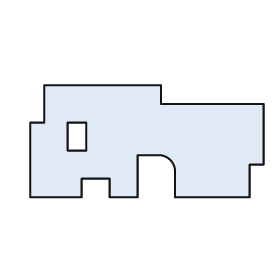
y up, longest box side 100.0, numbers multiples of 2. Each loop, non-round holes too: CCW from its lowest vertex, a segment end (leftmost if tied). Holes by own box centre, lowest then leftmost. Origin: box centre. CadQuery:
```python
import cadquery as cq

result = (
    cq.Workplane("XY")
    .moveTo(-50.0, -24.0)
    .lineTo(-28.0, -24.0)
    .lineTo(-28.0, -16.0)
    .lineTo(-16.0, -16.0)
    .lineTo(-16.0, -24.0)
    .lineTo(-4.0, -24.0)
    .lineTo(-4.0, -6.0)
    .lineTo(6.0, -6.0)
    .threePointArc((10.0, -8.0), (12.0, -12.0))
    .lineTo(12.0, -24.0)
    .lineTo(44.0, -24.0)
    .lineTo(44.0, -10.0)
    .lineTo(50.0, -10.0)
    .lineTo(50.0, 16.0)
    .lineTo(6.0, 16.0)
    .lineTo(6.0, 24.0)
    .lineTo(-44.0, 24.0)
    .lineTo(-44.0, 8.0)
    .lineTo(-50.0, 8.0)
    .close()
    .moveTo(-34.0, -4.0)
    .lineTo(-26.0, -4.0)
    .lineTo(-26.0, 8.0)
    .lineTo(-34.0, 8.0)
    .close()
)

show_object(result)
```